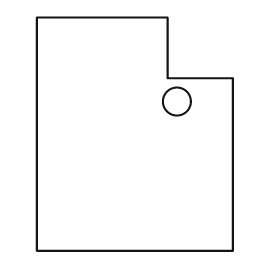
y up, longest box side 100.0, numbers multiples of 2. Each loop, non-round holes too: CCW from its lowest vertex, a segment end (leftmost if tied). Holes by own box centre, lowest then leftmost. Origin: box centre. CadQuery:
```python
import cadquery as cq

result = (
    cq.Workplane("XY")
    .moveTo(-42.0, -50.0)
    .lineTo(42.0, -50.0)
    .lineTo(42.0, 24.0)
    .lineTo(14.0, 24.0)
    .lineTo(14.0, 50.0)
    .lineTo(-42.0, 50.0)
    .close()
    .moveTo(18.0, 14.0)
    .circle(6.0)
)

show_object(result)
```